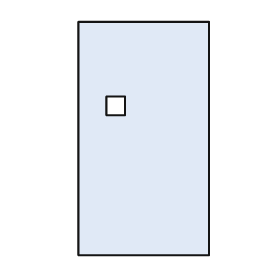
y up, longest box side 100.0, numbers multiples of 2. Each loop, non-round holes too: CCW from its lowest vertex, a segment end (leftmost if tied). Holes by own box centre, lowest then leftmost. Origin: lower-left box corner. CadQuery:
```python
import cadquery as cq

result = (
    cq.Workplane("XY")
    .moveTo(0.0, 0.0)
    .lineTo(56.0, 0.0)
    .lineTo(56.0, 100.0)
    .lineTo(0.0, 100.0)
    .close()
    .moveTo(12.0, 60.0)
    .lineTo(20.0, 60.0)
    .lineTo(20.0, 68.0)
    .lineTo(12.0, 68.0)
    .close()
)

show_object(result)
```